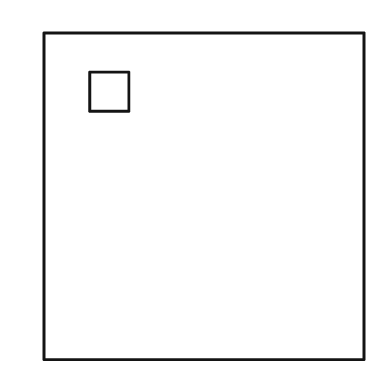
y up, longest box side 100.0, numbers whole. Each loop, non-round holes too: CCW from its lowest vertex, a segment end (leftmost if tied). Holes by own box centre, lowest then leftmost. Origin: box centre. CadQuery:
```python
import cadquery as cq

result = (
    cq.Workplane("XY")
    .moveTo(-49.0, -50.0)
    .lineTo(49.0, -50.0)
    .lineTo(49.0, 50.0)
    .lineTo(-49.0, 50.0)
    .close()
    .moveTo(-35.0, 26.0)
    .lineTo(-23.0, 26.0)
    .lineTo(-23.0, 38.0)
    .lineTo(-35.0, 38.0)
    .close()
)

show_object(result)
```